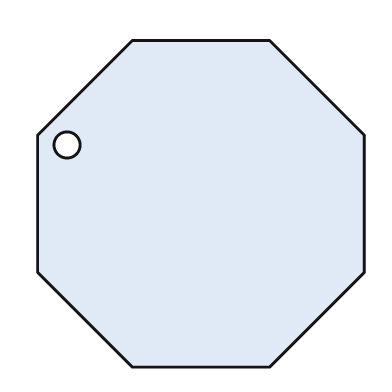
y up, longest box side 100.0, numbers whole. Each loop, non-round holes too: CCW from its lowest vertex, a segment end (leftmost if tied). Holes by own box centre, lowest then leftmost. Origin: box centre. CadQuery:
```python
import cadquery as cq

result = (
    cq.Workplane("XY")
    .moveTo(-21.0, -50.0)
    .lineTo(21.0, -50.0)
    .lineTo(50.0, -21.0)
    .lineTo(50.0, 21.0)
    .lineTo(21.0, 50.0)
    .lineTo(-21.0, 50.0)
    .lineTo(-50.0, 21.0)
    .lineTo(-50.0, -21.0)
    .close()
    .moveTo(-41.0, 18.0)
    .circle(4.0)
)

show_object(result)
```